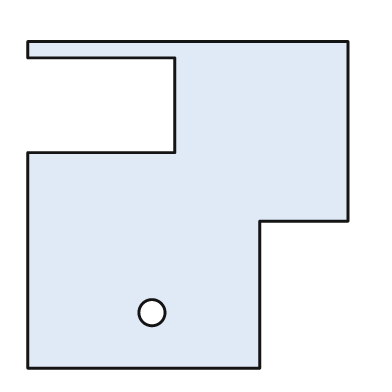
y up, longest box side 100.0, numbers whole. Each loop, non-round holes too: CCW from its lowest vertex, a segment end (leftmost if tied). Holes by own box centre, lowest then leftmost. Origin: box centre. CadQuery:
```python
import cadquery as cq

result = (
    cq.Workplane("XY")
    .moveTo(-49.0, -50.0)
    .lineTo(22.0, -50.0)
    .lineTo(22.0, -5.0)
    .lineTo(49.0, -5.0)
    .lineTo(49.0, 50.0)
    .lineTo(-49.0, 50.0)
    .lineTo(-49.0, 45.0)
    .lineTo(-4.0, 45.0)
    .lineTo(-4.0, 16.0)
    .lineTo(-49.0, 16.0)
    .close()
    .moveTo(-11.0, -33.0)
    .circle(4.0)
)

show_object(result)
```